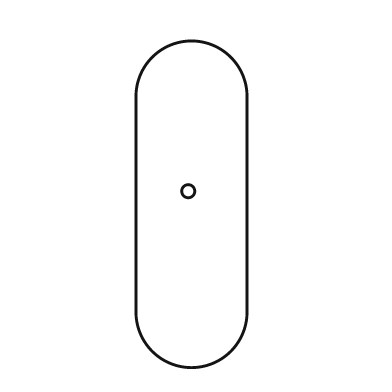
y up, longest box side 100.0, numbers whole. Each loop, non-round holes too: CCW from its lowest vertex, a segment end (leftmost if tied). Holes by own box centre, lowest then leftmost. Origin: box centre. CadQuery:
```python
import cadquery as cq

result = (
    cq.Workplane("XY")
    .moveTo(-17.0, -33.0)
    .threePointArc((0.0, -50.0), (17.0, -33.0))
    .lineTo(17.0, 33.0)
    .threePointArc((0.0, 50.0), (-17.0, 33.0))
    .close()
    .moveTo(-1.0, 4.0)
    .circle(2.0)
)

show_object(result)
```